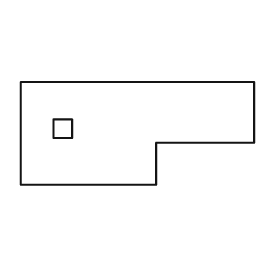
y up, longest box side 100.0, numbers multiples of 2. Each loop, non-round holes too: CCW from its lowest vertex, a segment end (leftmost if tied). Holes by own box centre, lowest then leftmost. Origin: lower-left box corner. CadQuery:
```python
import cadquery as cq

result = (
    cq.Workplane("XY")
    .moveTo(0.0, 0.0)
    .lineTo(58.0, 0.0)
    .lineTo(58.0, 18.0)
    .lineTo(100.0, 18.0)
    .lineTo(100.0, 44.0)
    .lineTo(0.0, 44.0)
    .close()
    .moveTo(14.0, 20.0)
    .lineTo(22.0, 20.0)
    .lineTo(22.0, 28.0)
    .lineTo(14.0, 28.0)
    .close()
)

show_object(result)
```